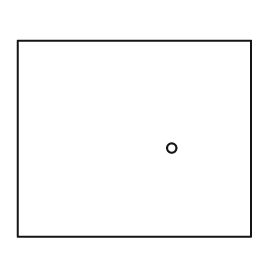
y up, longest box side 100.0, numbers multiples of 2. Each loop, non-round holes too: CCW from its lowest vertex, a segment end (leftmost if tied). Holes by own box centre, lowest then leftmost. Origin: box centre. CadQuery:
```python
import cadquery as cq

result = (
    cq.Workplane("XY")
    .moveTo(-50.0, -42.0)
    .lineTo(50.0, -42.0)
    .lineTo(50.0, 42.0)
    .lineTo(-50.0, 42.0)
    .close()
    .moveTo(16.0, -4.0)
    .circle(2.0)
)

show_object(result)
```